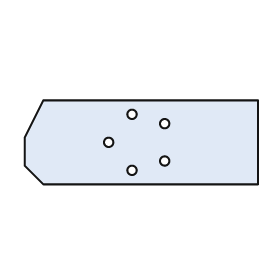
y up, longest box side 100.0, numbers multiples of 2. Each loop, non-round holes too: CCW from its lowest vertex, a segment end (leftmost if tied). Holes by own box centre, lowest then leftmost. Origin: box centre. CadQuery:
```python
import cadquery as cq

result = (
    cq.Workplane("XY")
    .moveTo(-42.0, -18.0)
    .lineTo(50.0, -18.0)
    .lineTo(50.0, 18.0)
    .lineTo(-42.0, 18.0)
    .lineTo(-50.0, 2.0)
    .lineTo(-50.0, -10.0)
    .close()
    .moveTo(-4.0, -12.0)
    .circle(2.0)
    .moveTo(10.0, -8.0)
    .circle(2.0)
    .moveTo(-14.0, 0.0)
    .circle(2.0)
    .moveTo(10.0, 8.0)
    .circle(2.0)
    .moveTo(-4.0, 12.0)
    .circle(2.0)
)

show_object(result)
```